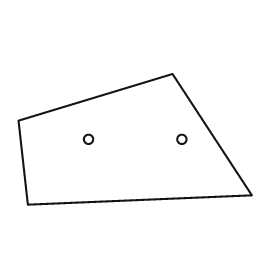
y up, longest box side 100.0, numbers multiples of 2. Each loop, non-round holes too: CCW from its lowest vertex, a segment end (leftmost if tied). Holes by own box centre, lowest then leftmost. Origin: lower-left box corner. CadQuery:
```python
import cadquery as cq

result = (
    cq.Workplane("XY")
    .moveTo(4.0, 0.0)
    .lineTo(100.0, 4.0)
    .lineTo(66.0, 56.0)
    .lineTo(0.0, 36.0)
    .close()
    .moveTo(30.0, 28.0)
    .circle(2.0)
    .moveTo(70.0, 28.0)
    .circle(2.0)
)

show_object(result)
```